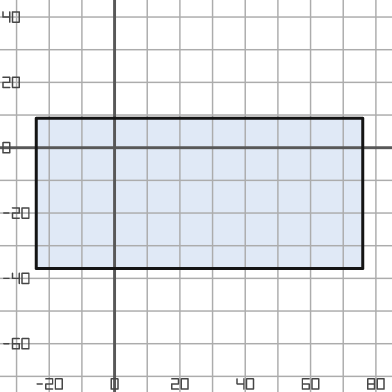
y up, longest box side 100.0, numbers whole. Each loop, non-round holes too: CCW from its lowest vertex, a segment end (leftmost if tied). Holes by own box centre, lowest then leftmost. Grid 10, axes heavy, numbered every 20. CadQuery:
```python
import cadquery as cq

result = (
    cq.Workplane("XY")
    .moveTo(-24.0, -37.0)
    .lineTo(76.0, -37.0)
    .lineTo(76.0, 9.0)
    .lineTo(-24.0, 9.0)
    .close()
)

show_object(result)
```